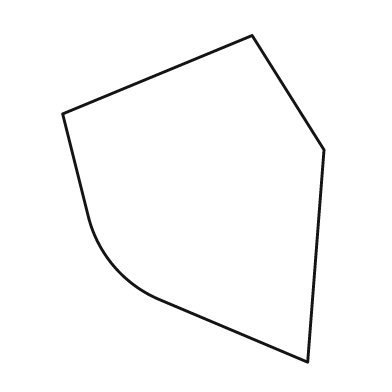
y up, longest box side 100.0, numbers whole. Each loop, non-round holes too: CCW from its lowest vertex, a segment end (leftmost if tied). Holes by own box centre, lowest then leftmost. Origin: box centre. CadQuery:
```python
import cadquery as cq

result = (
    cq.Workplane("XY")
    .moveTo(35.0, -50.0)
    .lineTo(40.0, 15.0)
    .lineTo(18.0, 50.0)
    .lineTo(-40.0, 26.0)
    .lineTo(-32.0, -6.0)
    .threePointArc((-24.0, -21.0), (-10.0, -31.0))
    .close()
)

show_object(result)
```